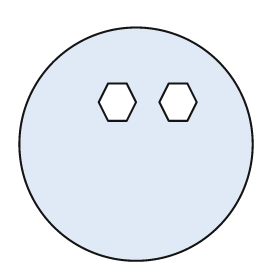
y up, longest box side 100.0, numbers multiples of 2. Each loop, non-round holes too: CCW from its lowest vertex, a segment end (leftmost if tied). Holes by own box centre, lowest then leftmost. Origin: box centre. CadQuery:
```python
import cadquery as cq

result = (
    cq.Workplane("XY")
    .moveTo(0.0, 0.0)
    .circle(50.0)
    .moveTo(-12.0, 10.0)
    .lineTo(-4.0, 10.0)
    .lineTo(0.0, 18.0)
    .lineTo(-4.0, 26.0)
    .lineTo(-12.0, 26.0)
    .lineTo(-16.0, 18.0)
    .close()
    .moveTo(14.0, 10.0)
    .lineTo(22.0, 10.0)
    .lineTo(26.0, 18.0)
    .lineTo(22.0, 26.0)
    .lineTo(14.0, 26.0)
    .lineTo(10.0, 18.0)
    .close()
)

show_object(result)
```